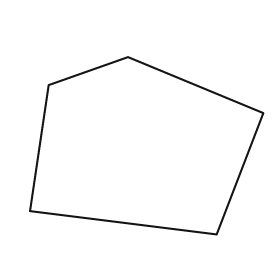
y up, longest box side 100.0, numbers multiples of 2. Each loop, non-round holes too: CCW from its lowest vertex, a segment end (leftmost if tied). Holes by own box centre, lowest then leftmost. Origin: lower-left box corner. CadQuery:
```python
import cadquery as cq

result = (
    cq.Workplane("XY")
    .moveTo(80.0, 0.0)
    .lineTo(100.0, 52.0)
    .lineTo(42.0, 76.0)
    .lineTo(8.0, 64.0)
    .lineTo(0.0, 10.0)
    .close()
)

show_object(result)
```